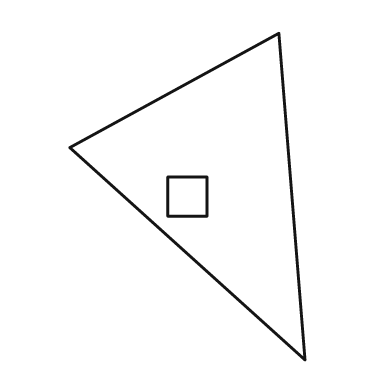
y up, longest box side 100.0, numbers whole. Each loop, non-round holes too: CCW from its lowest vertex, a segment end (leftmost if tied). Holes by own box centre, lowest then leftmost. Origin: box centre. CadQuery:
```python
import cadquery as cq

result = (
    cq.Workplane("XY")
    .moveTo(36.0, -50.0)
    .lineTo(28.0, 50.0)
    .lineTo(-36.0, 15.0)
    .close()
    .moveTo(-6.0, -6.0)
    .lineTo(6.0, -6.0)
    .lineTo(6.0, 6.0)
    .lineTo(-6.0, 6.0)
    .close()
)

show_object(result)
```